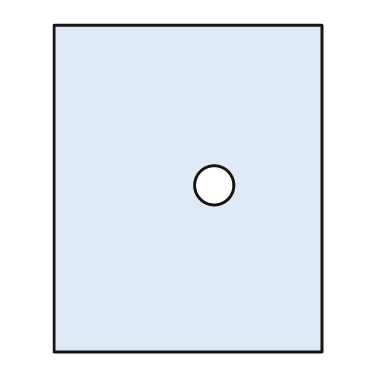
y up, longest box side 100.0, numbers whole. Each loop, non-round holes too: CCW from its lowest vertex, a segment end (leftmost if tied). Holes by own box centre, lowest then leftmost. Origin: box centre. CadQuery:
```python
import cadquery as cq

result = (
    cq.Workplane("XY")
    .moveTo(-41.0, -50.0)
    .lineTo(41.0, -50.0)
    .lineTo(41.0, 50.0)
    .lineTo(-41.0, 50.0)
    .close()
    .moveTo(8.0, 1.0)
    .circle(6.0)
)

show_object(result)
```